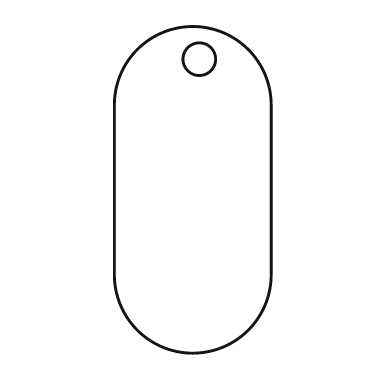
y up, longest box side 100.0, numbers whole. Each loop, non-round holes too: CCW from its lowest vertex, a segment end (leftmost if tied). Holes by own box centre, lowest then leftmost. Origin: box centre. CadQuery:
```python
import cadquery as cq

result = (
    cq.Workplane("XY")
    .moveTo(-24.0, -26.0)
    .threePointArc((0.0, -50.0), (24.0, -26.0))
    .lineTo(24.0, 26.0)
    .threePointArc((0.0, 50.0), (-24.0, 26.0))
    .close()
    .moveTo(2.0, 40.0)
    .circle(5.0)
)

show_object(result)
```